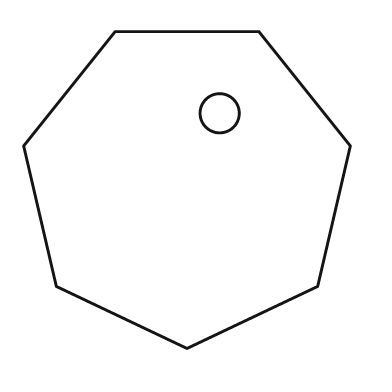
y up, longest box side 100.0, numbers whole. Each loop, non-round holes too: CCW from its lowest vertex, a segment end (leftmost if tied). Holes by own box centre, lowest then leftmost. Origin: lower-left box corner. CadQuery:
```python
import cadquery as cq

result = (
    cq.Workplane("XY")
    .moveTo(50.0, 0.0)
    .lineTo(90.0, 19.0)
    .lineTo(100.0, 62.0)
    .lineTo(72.0, 97.0)
    .lineTo(28.0, 97.0)
    .lineTo(0.0, 62.0)
    .lineTo(10.0, 19.0)
    .close()
    .moveTo(60.0, 72.0)
    .circle(6.0)
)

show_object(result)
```